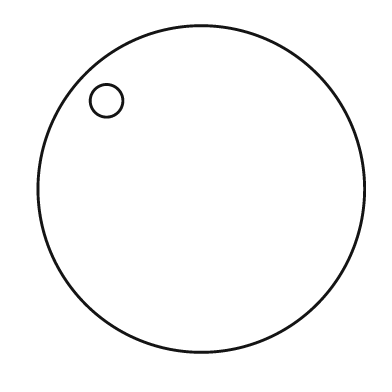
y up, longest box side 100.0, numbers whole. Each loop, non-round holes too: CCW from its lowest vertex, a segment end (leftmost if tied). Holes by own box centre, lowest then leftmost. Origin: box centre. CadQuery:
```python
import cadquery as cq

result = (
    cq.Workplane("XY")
    .moveTo(0.0, 0.0)
    .circle(50.0)
    .moveTo(-29.0, 27.0)
    .circle(5.0)
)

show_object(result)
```